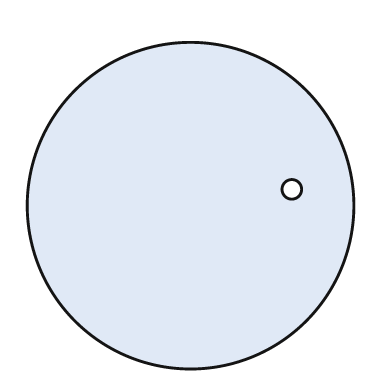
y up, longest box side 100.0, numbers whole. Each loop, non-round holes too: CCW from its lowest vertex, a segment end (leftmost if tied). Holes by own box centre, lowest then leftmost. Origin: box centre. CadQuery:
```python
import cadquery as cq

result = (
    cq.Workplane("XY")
    .moveTo(0.0, 0.0)
    .circle(50.0)
    .moveTo(31.0, 5.0)
    .circle(3.0)
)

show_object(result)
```